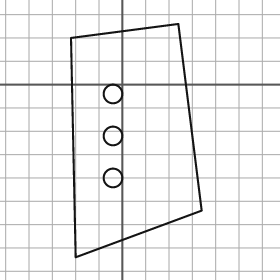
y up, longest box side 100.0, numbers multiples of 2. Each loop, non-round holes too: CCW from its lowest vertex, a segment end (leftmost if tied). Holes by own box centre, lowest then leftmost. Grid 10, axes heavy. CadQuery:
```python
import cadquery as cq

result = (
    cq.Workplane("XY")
    .moveTo(-20.0, -74.0)
    .lineTo(34.0, -54.0)
    .lineTo(24.0, 26.0)
    .lineTo(-22.0, 20.0)
    .close()
    .moveTo(-4.0, -40.0)
    .circle(4.0)
    .moveTo(-4.0, -22.0)
    .circle(4.0)
    .moveTo(-4.0, -4.0)
    .circle(4.0)
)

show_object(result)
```